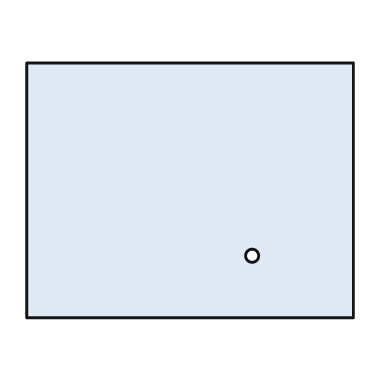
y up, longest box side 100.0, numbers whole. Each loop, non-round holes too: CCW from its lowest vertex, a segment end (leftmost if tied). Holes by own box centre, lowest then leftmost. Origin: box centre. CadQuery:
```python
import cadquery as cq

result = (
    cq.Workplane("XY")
    .moveTo(-50.0, -39.0)
    .lineTo(50.0, -39.0)
    .lineTo(50.0, 39.0)
    .lineTo(-50.0, 39.0)
    .close()
    .moveTo(19.0, -20.0)
    .circle(2.0)
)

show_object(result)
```